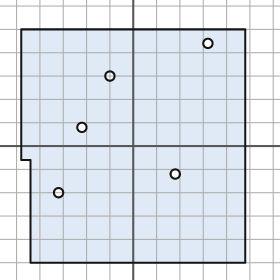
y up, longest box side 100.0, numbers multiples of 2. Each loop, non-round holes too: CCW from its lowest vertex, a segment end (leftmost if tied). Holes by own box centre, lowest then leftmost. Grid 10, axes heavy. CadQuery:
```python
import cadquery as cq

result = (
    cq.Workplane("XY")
    .moveTo(-44.0, -50.0)
    .lineTo(48.0, -50.0)
    .lineTo(48.0, 50.0)
    .lineTo(-48.0, 50.0)
    .lineTo(-48.0, -6.0)
    .lineTo(-44.0, -6.0)
    .close()
    .moveTo(-32.0, -20.0)
    .circle(2.0)
    .moveTo(18.0, -12.0)
    .circle(2.0)
    .moveTo(-22.0, 8.0)
    .circle(2.0)
    .moveTo(-10.0, 30.0)
    .circle(2.0)
    .moveTo(32.0, 44.0)
    .circle(2.0)
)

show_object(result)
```